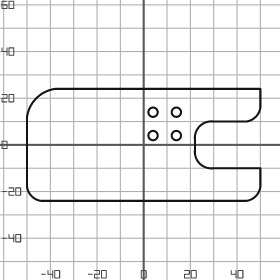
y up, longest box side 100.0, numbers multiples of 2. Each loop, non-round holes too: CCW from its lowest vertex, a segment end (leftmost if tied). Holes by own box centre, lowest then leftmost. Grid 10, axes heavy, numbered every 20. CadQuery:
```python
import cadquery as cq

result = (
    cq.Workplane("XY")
    .moveTo(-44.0, -24.0)
    .lineTo(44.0, -24.0)
    .threePointArc((48.0, -22.0), (50.0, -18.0))
    .lineTo(50.0, -10.0)
    .lineTo(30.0, -10.0)
    .threePointArc((24.0, -8.0), (22.0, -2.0))
    .lineTo(22.0, 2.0)
    .threePointArc((24.0, 8.0), (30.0, 10.0))
    .lineTo(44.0, 10.0)
    .threePointArc((48.0, 12.0), (50.0, 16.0))
    .lineTo(50.0, 24.0)
    .lineTo(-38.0, 24.0)
    .threePointArc((-46.0, 20.0), (-50.0, 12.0))
    .lineTo(-50.0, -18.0)
    .threePointArc((-48.0, -22.0), (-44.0, -24.0))
    .close()
    .moveTo(4.0, 4.0)
    .circle(2.0)
    .moveTo(14.0, 4.0)
    .circle(2.0)
    .moveTo(4.0, 14.0)
    .circle(2.0)
    .moveTo(14.0, 14.0)
    .circle(2.0)
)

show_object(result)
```